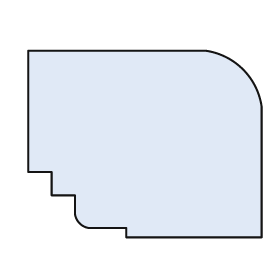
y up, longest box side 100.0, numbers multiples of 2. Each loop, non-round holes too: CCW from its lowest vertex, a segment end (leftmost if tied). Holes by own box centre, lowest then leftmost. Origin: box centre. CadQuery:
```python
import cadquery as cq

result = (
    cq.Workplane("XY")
    .moveTo(-8.0, -40.0)
    .lineTo(50.0, -40.0)
    .lineTo(50.0, 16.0)
    .threePointArc((42.0, 32.0), (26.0, 40.0))
    .lineTo(-50.0, 40.0)
    .lineTo(-50.0, -12.0)
    .lineTo(-40.0, -12.0)
    .lineTo(-40.0, -22.0)
    .lineTo(-30.0, -22.0)
    .lineTo(-30.0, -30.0)
    .threePointArc((-28.0, -34.0), (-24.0, -36.0))
    .lineTo(-8.0, -36.0)
    .close()
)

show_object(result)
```